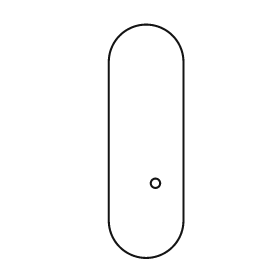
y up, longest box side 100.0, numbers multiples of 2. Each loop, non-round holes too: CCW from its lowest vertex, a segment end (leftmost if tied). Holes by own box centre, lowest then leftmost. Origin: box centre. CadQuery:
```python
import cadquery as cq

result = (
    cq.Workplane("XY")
    .moveTo(-16.0, -34.0)
    .threePointArc((0.0, -50.0), (16.0, -34.0))
    .lineTo(16.0, 34.0)
    .threePointArc((0.0, 50.0), (-16.0, 34.0))
    .close()
    .moveTo(4.0, -18.0)
    .circle(2.0)
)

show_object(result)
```